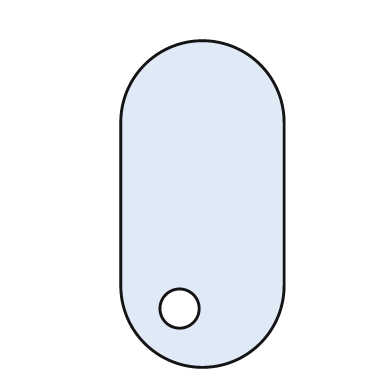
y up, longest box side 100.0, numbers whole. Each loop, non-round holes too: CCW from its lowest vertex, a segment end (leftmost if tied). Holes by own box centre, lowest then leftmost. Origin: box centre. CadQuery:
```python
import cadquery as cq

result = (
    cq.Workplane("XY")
    .moveTo(-25.0, -25.0)
    .threePointArc((0.0, -50.0), (25.0, -25.0))
    .lineTo(25.0, 25.0)
    .threePointArc((0.0, 50.0), (-25.0, 25.0))
    .close()
    .moveTo(-7.0, -32.0)
    .circle(6.0)
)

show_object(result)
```